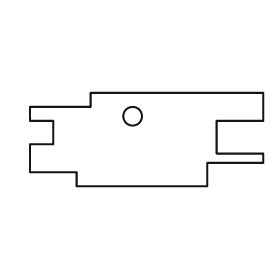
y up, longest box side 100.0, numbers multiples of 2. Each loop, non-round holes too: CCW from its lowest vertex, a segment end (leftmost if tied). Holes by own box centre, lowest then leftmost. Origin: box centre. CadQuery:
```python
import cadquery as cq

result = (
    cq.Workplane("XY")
    .moveTo(-30.0, -20.0)
    .lineTo(26.0, -20.0)
    .lineTo(26.0, -10.0)
    .lineTo(50.0, -10.0)
    .lineTo(50.0, -6.0)
    .lineTo(30.0, -6.0)
    .lineTo(30.0, 8.0)
    .lineTo(50.0, 8.0)
    .lineTo(50.0, 20.0)
    .lineTo(-24.0, 20.0)
    .lineTo(-24.0, 14.0)
    .lineTo(-50.0, 14.0)
    .lineTo(-50.0, 8.0)
    .lineTo(-40.0, 8.0)
    .lineTo(-40.0, -2.0)
    .lineTo(-50.0, -2.0)
    .lineTo(-50.0, -14.0)
    .lineTo(-30.0, -14.0)
    .close()
    .moveTo(-6.0, 10.0)
    .circle(4.0)
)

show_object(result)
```